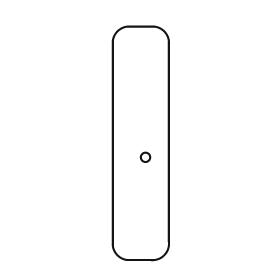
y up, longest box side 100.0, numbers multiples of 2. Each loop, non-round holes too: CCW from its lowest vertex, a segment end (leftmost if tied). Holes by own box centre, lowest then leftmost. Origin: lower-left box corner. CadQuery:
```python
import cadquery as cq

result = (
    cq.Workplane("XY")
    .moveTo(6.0, 0.0)
    .lineTo(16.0, 0.0)
    .threePointArc((22.0, 2.0), (24.0, 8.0))
    .lineTo(24.0, 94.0)
    .threePointArc((22.0, 98.0), (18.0, 100.0))
    .lineTo(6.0, 100.0)
    .threePointArc((2.0, 98.0), (0.0, 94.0))
    .lineTo(0.0, 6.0)
    .threePointArc((2.0, 2.0), (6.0, 0.0))
    .close()
    .moveTo(14.0, 44.0)
    .circle(2.0)
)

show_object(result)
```